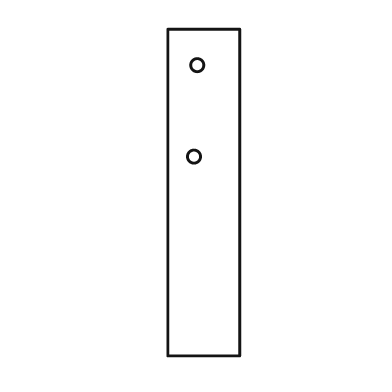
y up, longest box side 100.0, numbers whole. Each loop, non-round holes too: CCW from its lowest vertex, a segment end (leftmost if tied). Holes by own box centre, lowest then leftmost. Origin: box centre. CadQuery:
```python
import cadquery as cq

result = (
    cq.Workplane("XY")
    .moveTo(-11.0, -50.0)
    .lineTo(11.0, -50.0)
    .lineTo(11.0, 50.0)
    .lineTo(-11.0, 50.0)
    .close()
    .moveTo(-3.0, 11.0)
    .circle(2.0)
    .moveTo(-2.0, 39.0)
    .circle(2.0)
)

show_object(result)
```